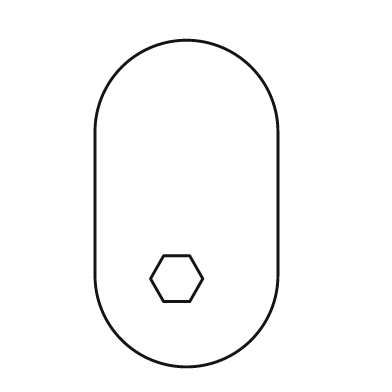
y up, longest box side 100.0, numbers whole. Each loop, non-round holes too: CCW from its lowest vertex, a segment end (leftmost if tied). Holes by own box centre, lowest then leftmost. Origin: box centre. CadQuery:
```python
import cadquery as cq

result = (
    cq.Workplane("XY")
    .moveTo(-28.0, -22.0)
    .threePointArc((0.0, -50.0), (28.0, -22.0))
    .lineTo(28.0, 22.0)
    .threePointArc((0.0, 50.0), (-28.0, 22.0))
    .close()
    .moveTo(-7.0, -30.0)
    .lineTo(1.0, -30.0)
    .lineTo(5.0, -23.0)
    .lineTo(1.0, -16.0)
    .lineTo(-7.0, -16.0)
    .lineTo(-11.0, -23.0)
    .close()
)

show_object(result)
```